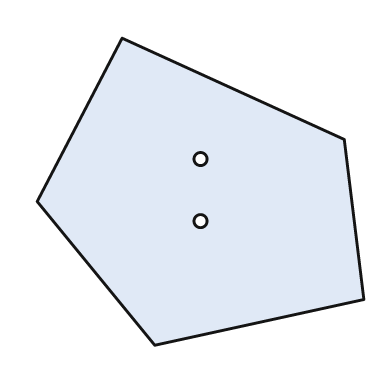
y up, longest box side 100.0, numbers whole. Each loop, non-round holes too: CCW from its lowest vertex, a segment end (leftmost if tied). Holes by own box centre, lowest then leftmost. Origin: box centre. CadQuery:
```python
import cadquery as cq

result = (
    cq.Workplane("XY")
    .moveTo(-14.0, -47.0)
    .lineTo(50.0, -33.0)
    .lineTo(44.0, 16.0)
    .lineTo(-24.0, 47.0)
    .lineTo(-50.0, -3.0)
    .close()
    .moveTo(0.0, -9.0)
    .circle(2.0)
    .moveTo(0.0, 10.0)
    .circle(2.0)
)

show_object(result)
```